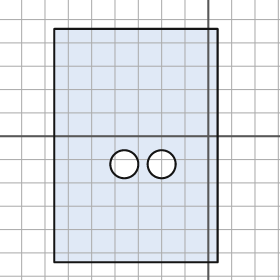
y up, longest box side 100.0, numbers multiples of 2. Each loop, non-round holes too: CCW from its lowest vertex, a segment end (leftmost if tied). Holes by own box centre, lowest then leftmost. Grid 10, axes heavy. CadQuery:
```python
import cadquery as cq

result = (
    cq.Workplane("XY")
    .moveTo(-66.0, -54.0)
    .lineTo(4.0, -54.0)
    .lineTo(4.0, 46.0)
    .lineTo(-66.0, 46.0)
    .close()
    .moveTo(-36.0, -12.0)
    .circle(6.0)
    .moveTo(-20.0, -12.0)
    .circle(6.0)
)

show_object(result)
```